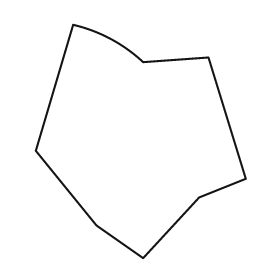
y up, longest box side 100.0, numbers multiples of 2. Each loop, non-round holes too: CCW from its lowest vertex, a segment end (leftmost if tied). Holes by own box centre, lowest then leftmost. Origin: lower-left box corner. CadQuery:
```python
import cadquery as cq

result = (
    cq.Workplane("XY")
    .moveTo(46.0, 0.0)
    .lineTo(70.0, 26.0)
    .lineTo(90.0, 34.0)
    .lineTo(74.0, 86.0)
    .lineTo(46.0, 84.0)
    .threePointArc((32.0, 94.0), (16.0, 100.0))
    .lineTo(0.0, 46.0)
    .lineTo(26.0, 14.0)
    .close()
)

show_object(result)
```